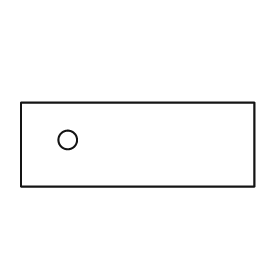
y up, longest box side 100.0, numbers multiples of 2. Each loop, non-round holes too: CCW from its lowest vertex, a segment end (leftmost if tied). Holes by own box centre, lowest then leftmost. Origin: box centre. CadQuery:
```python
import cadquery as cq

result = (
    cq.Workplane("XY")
    .moveTo(-50.0, -18.0)
    .lineTo(50.0, -18.0)
    .lineTo(50.0, 18.0)
    .lineTo(-50.0, 18.0)
    .close()
    .moveTo(-30.0, 2.0)
    .circle(4.0)
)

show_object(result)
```